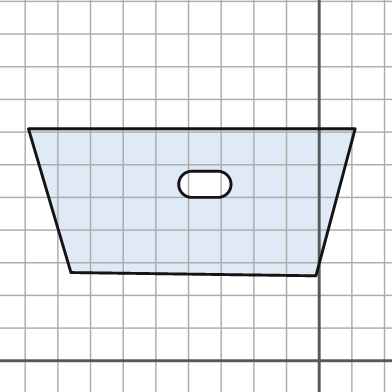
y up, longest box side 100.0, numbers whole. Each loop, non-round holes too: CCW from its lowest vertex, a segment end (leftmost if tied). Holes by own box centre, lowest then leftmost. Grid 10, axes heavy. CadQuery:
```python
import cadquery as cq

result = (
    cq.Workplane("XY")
    .moveTo(-1.0, 26.0)
    .lineTo(11.0, 71.0)
    .lineTo(-89.0, 71.0)
    .lineTo(-76.0, 27.0)
    .close()
    .moveTo(-39.0, 50.0)
    .lineTo(-31.0, 50.0)
    .threePointArc((-27.0, 54.0), (-31.0, 58.0))
    .lineTo(-39.0, 58.0)
    .threePointArc((-43.0, 54.0), (-39.0, 50.0))
    .close()
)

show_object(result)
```